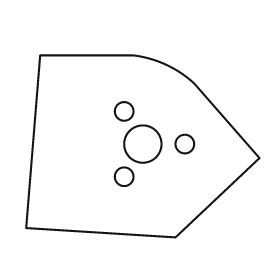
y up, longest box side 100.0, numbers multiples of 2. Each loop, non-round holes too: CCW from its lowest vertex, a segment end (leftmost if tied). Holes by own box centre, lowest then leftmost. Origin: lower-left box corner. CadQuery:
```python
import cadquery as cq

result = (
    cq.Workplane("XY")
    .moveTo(64.0, 0.0)
    .lineTo(100.0, 34.0)
    .lineTo(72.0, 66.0)
    .threePointArc((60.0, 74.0), (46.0, 78.0))
    .lineTo(6.0, 78.0)
    .lineTo(0.0, 4.0)
    .close()
    .moveTo(42.0, 26.0)
    .circle(4.0)
    .moveTo(50.0, 40.0)
    .circle(8.0)
    .moveTo(68.0, 40.0)
    .circle(4.0)
    .moveTo(42.0, 54.0)
    .circle(4.0)
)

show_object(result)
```